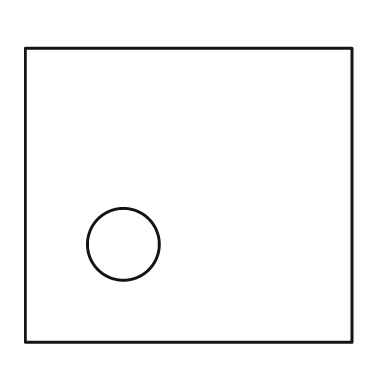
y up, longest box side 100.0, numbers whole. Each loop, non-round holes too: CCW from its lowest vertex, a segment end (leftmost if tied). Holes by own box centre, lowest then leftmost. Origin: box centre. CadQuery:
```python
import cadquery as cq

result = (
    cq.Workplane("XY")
    .moveTo(-50.0, -45.0)
    .lineTo(50.0, -45.0)
    .lineTo(50.0, 45.0)
    .lineTo(-50.0, 45.0)
    .close()
    .moveTo(-20.0, -15.0)
    .circle(11.0)
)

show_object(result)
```